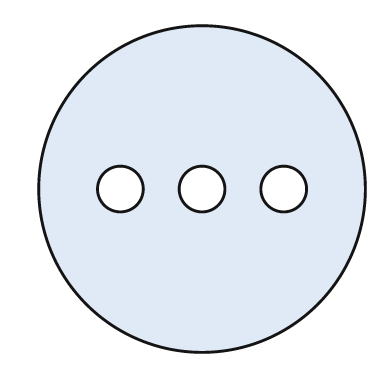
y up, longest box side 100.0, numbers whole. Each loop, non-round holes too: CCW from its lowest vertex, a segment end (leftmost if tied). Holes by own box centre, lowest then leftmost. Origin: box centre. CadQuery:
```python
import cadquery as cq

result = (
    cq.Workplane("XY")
    .moveTo(0.0, 0.0)
    .circle(50.0)
    .moveTo(-25.0, 0.0)
    .circle(7.0)
    .moveTo(0.0, 0.0)
    .circle(7.0)
    .moveTo(25.0, 0.0)
    .circle(7.0)
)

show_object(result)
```